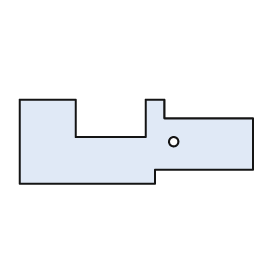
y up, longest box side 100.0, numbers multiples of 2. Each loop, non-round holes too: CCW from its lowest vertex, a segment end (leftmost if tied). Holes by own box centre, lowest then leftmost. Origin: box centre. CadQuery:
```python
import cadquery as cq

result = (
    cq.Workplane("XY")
    .moveTo(-50.0, -18.0)
    .lineTo(8.0, -18.0)
    .lineTo(8.0, -12.0)
    .lineTo(50.0, -12.0)
    .lineTo(50.0, 10.0)
    .lineTo(12.0, 10.0)
    .lineTo(12.0, 18.0)
    .lineTo(4.0, 18.0)
    .lineTo(4.0, 2.0)
    .lineTo(-26.0, 2.0)
    .lineTo(-26.0, 18.0)
    .lineTo(-50.0, 18.0)
    .close()
    .moveTo(16.0, 0.0)
    .circle(2.0)
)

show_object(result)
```